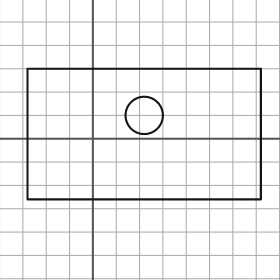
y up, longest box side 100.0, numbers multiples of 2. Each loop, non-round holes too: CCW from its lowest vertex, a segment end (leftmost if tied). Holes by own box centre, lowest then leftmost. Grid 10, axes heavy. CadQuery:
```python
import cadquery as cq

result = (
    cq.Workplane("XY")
    .moveTo(-28.0, -26.0)
    .lineTo(72.0, -26.0)
    .lineTo(72.0, 30.0)
    .lineTo(-28.0, 30.0)
    .close()
    .moveTo(22.0, 10.0)
    .circle(8.0)
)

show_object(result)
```